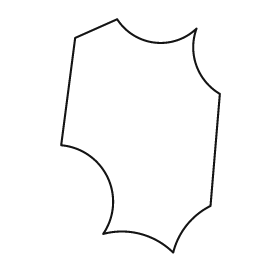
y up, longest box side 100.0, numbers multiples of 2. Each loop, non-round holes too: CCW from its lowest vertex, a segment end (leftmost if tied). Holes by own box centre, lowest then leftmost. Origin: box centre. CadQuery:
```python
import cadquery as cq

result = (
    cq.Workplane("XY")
    .moveTo(14.0, -50.0)
    .threePointArc((20.0, -38.0), (30.0, -30.0))
    .lineTo(34.0, 18.0)
    .threePointArc((24.0, 30.0), (24.0, 46.0))
    .threePointArc((6.0, 40.0), (-10.0, 50.0))
    .lineTo(-28.0, 42.0)
    .lineTo(-34.0, -4.0)
    .threePointArc((-14.0, -18.0), (-16.0, -42.0))
    .threePointArc((0.0, -42.0), (14.0, -50.0))
    .close()
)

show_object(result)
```